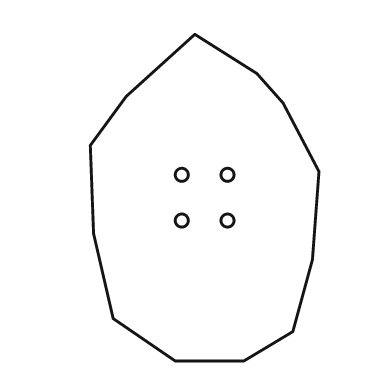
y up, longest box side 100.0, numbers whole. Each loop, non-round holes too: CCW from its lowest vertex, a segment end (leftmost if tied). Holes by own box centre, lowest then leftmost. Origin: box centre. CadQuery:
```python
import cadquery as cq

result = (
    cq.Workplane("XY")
    .moveTo(-9.0, -50.0)
    .lineTo(12.0, -50.0)
    .lineTo(27.0, -41.0)
    .lineTo(33.0, -19.0)
    .lineTo(35.0, 8.0)
    .lineTo(24.0, 29.0)
    .lineTo(16.0, 38.0)
    .lineTo(-3.0, 50.0)
    .lineTo(-24.0, 31.0)
    .lineTo(-35.0, 16.0)
    .lineTo(-34.0, -11.0)
    .lineTo(-28.0, -37.0)
    .close()
    .moveTo(-7.0, -7.0)
    .circle(2.0)
    .moveTo(7.0, -7.0)
    .circle(2.0)
    .moveTo(-7.0, 7.0)
    .circle(2.0)
    .moveTo(7.0, 7.0)
    .circle(2.0)
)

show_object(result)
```